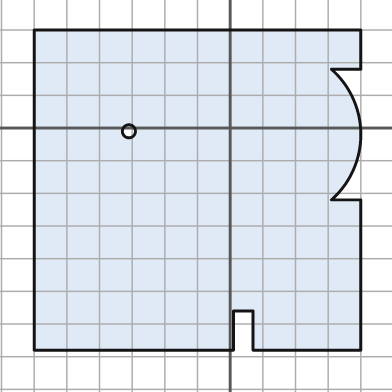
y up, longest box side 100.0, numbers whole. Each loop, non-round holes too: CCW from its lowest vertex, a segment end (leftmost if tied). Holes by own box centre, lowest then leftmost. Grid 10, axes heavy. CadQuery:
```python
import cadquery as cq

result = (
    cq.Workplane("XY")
    .moveTo(-60.0, -68.0)
    .lineTo(1.0, -68.0)
    .lineTo(1.0, -56.0)
    .lineTo(7.0, -56.0)
    .lineTo(7.0, -68.0)
    .lineTo(40.0, -68.0)
    .lineTo(40.0, -22.0)
    .lineTo(31.0, -22.0)
    .threePointArc((40.0, -2.0), (31.0, 18.0))
    .lineTo(40.0, 18.0)
    .lineTo(40.0, 30.0)
    .lineTo(-60.0, 30.0)
    .close()
    .moveTo(-31.0, -1.0)
    .circle(2.0)
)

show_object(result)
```